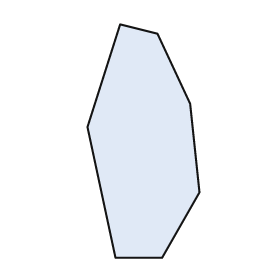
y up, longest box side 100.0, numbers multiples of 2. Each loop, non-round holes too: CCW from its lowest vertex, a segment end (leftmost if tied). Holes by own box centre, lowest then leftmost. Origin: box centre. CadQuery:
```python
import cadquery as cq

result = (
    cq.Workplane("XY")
    .moveTo(-12.0, -50.0)
    .lineTo(8.0, -50.0)
    .lineTo(24.0, -22.0)
    .lineTo(20.0, 16.0)
    .lineTo(6.0, 46.0)
    .lineTo(-10.0, 50.0)
    .lineTo(-24.0, 6.0)
    .close()
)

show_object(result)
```